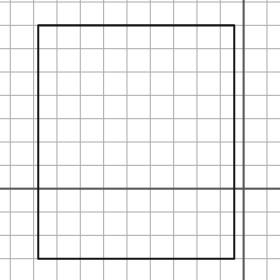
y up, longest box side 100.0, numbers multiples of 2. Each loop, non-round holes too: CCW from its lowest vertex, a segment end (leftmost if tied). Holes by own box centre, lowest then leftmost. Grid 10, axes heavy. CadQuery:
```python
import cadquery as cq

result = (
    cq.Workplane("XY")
    .moveTo(-88.0, -30.0)
    .lineTo(-4.0, -30.0)
    .lineTo(-4.0, 70.0)
    .lineTo(-88.0, 70.0)
    .close()
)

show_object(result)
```